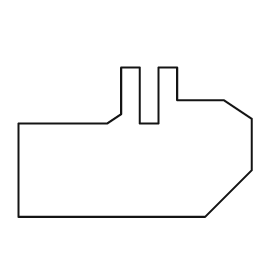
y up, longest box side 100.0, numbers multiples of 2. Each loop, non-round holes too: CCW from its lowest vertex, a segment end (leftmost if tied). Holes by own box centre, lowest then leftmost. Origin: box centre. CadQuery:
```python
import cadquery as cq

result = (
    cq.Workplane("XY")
    .moveTo(-50.0, -32.0)
    .lineTo(30.0, -32.0)
    .lineTo(50.0, -12.0)
    .lineTo(50.0, 10.0)
    .lineTo(38.0, 18.0)
    .lineTo(18.0, 18.0)
    .lineTo(18.0, 32.0)
    .lineTo(10.0, 32.0)
    .lineTo(10.0, 8.0)
    .lineTo(2.0, 8.0)
    .lineTo(2.0, 32.0)
    .lineTo(-6.0, 32.0)
    .lineTo(-6.0, 12.0)
    .lineTo(-12.0, 8.0)
    .lineTo(-50.0, 8.0)
    .close()
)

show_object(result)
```